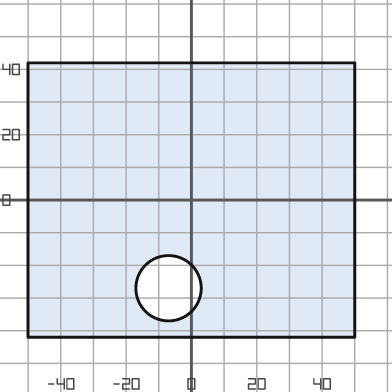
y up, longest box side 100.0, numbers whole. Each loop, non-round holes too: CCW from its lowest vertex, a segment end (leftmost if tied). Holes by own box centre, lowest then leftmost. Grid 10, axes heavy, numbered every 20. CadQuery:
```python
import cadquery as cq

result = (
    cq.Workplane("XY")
    .moveTo(-50.0, -42.0)
    .lineTo(50.0, -42.0)
    .lineTo(50.0, 42.0)
    .lineTo(-50.0, 42.0)
    .close()
    .moveTo(-7.0, -27.0)
    .circle(10.0)
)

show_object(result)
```